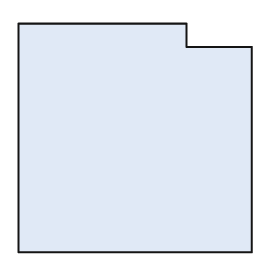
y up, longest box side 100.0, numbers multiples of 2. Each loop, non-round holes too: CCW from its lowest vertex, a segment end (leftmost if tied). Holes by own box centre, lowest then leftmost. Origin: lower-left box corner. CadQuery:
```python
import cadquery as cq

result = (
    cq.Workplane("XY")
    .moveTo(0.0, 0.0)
    .lineTo(100.0, 0.0)
    .lineTo(100.0, 88.0)
    .lineTo(72.0, 88.0)
    .lineTo(72.0, 98.0)
    .lineTo(0.0, 98.0)
    .close()
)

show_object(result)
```